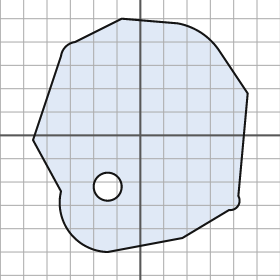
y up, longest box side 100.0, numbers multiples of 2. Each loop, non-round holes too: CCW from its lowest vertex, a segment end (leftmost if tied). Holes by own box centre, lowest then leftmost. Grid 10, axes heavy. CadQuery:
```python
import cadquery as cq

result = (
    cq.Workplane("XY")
    .moveTo(-14.0, -50.0)
    .lineTo(18.0, -44.0)
    .lineTo(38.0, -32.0)
    .threePointArc((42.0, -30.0), (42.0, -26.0))
    .lineTo(46.0, 18.0)
    .lineTo(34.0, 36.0)
    .threePointArc((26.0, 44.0), (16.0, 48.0))
    .lineTo(-8.0, 50.0)
    .lineTo(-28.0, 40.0)
    .threePointArc((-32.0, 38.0), (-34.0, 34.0))
    .lineTo(-46.0, -2.0)
    .lineTo(-34.0, -24.0)
    .threePointArc((-30.0, -42.0), (-14.0, -50.0))
    .close()
    .moveTo(-14.0, -22.0)
    .circle(6.0)
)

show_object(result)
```